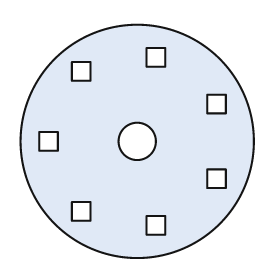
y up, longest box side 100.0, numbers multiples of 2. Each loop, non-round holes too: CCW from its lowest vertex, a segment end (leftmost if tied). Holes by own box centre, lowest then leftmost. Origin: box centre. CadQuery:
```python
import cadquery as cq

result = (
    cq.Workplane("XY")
    .moveTo(0.0, 0.0)
    .circle(50.0)
    .moveTo(4.0, -40.0)
    .lineTo(12.0, -40.0)
    .lineTo(12.0, -32.0)
    .lineTo(4.0, -32.0)
    .close()
    .moveTo(-28.0, -34.0)
    .lineTo(-20.0, -34.0)
    .lineTo(-20.0, -26.0)
    .lineTo(-28.0, -26.0)
    .close()
    .moveTo(30.0, -20.0)
    .lineTo(38.0, -20.0)
    .lineTo(38.0, -12.0)
    .lineTo(30.0, -12.0)
    .close()
    .moveTo(-42.0, -4.0)
    .lineTo(-34.0, -4.0)
    .lineTo(-34.0, 4.0)
    .lineTo(-42.0, 4.0)
    .close()
    .moveTo(0.0, 0.0)
    .circle(8.0)
    .moveTo(30.0, 12.0)
    .lineTo(38.0, 12.0)
    .lineTo(38.0, 20.0)
    .lineTo(30.0, 20.0)
    .close()
    .moveTo(-28.0, 26.0)
    .lineTo(-20.0, 26.0)
    .lineTo(-20.0, 34.0)
    .lineTo(-28.0, 34.0)
    .close()
    .moveTo(4.0, 32.0)
    .lineTo(12.0, 32.0)
    .lineTo(12.0, 40.0)
    .lineTo(4.0, 40.0)
    .close()
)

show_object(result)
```